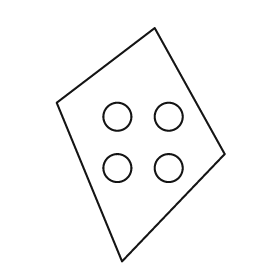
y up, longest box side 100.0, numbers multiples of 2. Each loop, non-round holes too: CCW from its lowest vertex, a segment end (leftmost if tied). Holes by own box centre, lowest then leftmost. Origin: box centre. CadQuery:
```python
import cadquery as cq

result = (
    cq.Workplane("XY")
    .moveTo(-8.0, -50.0)
    .lineTo(36.0, -4.0)
    .lineTo(6.0, 50.0)
    .lineTo(-36.0, 18.0)
    .close()
    .moveTo(-10.0, -10.0)
    .circle(6.0)
    .moveTo(12.0, -10.0)
    .circle(6.0)
    .moveTo(-10.0, 12.0)
    .circle(6.0)
    .moveTo(12.0, 12.0)
    .circle(6.0)
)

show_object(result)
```